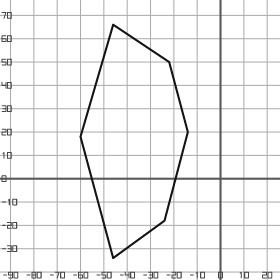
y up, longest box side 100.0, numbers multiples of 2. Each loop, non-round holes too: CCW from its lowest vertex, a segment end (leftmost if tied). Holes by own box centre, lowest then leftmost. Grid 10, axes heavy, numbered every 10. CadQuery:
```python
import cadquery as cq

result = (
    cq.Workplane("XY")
    .moveTo(-46.0, -34.0)
    .lineTo(-24.0, -18.0)
    .lineTo(-14.0, 20.0)
    .lineTo(-22.0, 50.0)
    .lineTo(-46.0, 66.0)
    .lineTo(-60.0, 18.0)
    .close()
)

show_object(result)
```